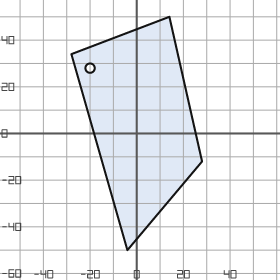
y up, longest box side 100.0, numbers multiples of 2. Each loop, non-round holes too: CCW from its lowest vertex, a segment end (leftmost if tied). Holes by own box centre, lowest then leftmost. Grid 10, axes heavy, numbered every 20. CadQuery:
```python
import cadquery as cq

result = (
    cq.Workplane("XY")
    .moveTo(-4.0, -50.0)
    .lineTo(28.0, -12.0)
    .lineTo(14.0, 50.0)
    .lineTo(-28.0, 34.0)
    .close()
    .moveTo(-20.0, 28.0)
    .circle(2.0)
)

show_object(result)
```